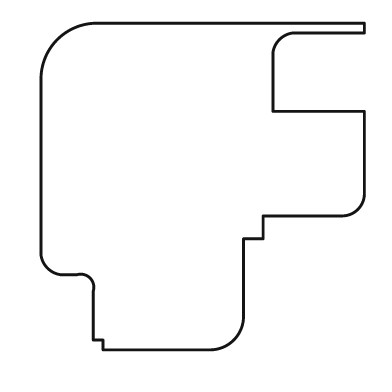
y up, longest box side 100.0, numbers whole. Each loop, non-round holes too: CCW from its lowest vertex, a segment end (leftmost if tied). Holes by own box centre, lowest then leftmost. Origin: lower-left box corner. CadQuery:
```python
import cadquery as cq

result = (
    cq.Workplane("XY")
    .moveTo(19.0, 0.0)
    .lineTo(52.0, 0.0)
    .threePointArc((59.0, 3.0), (62.0, 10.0))
    .lineTo(62.0, 34.0)
    .lineTo(68.0, 34.0)
    .lineTo(68.0, 41.0)
    .lineTo(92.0, 41.0)
    .threePointArc((97.0, 43.0), (99.0, 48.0))
    .lineTo(99.0, 73.0)
    .lineTo(71.0, 73.0)
    .lineTo(71.0, 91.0)
    .threePointArc((73.0, 95.0), (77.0, 97.0))
    .lineTo(99.0, 97.0)
    .lineTo(99.0, 100.0)
    .lineTo(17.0, 100.0)
    .threePointArc((5.0, 95.0), (0.0, 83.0))
    .lineTo(0.0, 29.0)
    .threePointArc((2.0, 25.0), (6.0, 23.0))
    .lineTo(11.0, 23.0)
    .threePointArc((15.0, 22.0), (16.0, 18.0))
    .lineTo(16.0, 3.0)
    .lineTo(19.0, 3.0)
    .close()
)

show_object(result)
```